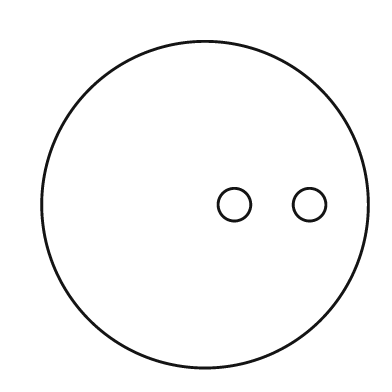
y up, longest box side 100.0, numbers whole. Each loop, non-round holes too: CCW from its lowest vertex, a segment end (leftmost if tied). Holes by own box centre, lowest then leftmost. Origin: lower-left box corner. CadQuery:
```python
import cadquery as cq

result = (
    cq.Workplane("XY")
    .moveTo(50.0, 50.0)
    .circle(50.0)
    .moveTo(59.0, 50.0)
    .circle(5.0)
    .moveTo(82.0, 50.0)
    .circle(5.0)
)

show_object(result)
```